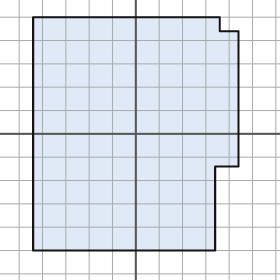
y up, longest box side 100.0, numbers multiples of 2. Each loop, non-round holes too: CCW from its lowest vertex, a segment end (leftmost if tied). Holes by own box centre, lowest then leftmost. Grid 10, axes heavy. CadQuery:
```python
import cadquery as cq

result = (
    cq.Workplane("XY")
    .moveTo(-44.0, -50.0)
    .lineTo(34.0, -50.0)
    .lineTo(34.0, -14.0)
    .lineTo(44.0, -14.0)
    .lineTo(44.0, 44.0)
    .lineTo(36.0, 44.0)
    .lineTo(36.0, 50.0)
    .lineTo(-44.0, 50.0)
    .close()
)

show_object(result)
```